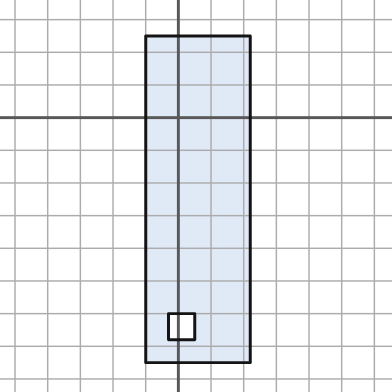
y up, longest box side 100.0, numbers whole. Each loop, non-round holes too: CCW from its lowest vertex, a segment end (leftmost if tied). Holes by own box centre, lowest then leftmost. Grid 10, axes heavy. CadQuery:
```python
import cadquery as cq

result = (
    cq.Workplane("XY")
    .moveTo(-10.0, -75.0)
    .lineTo(22.0, -75.0)
    .lineTo(22.0, 25.0)
    .lineTo(-10.0, 25.0)
    .close()
    .moveTo(-3.0, -68.0)
    .lineTo(5.0, -68.0)
    .lineTo(5.0, -60.0)
    .lineTo(-3.0, -60.0)
    .close()
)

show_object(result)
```